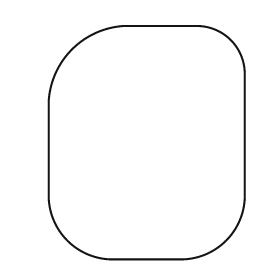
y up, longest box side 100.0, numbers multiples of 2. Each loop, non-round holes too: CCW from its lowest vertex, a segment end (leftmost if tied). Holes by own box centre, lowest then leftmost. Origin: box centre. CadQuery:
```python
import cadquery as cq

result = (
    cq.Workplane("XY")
    .moveTo(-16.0, -50.0)
    .lineTo(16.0, -50.0)
    .threePointArc((34.0, -42.0), (42.0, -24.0))
    .lineTo(42.0, 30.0)
    .threePointArc((36.0, 44.0), (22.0, 50.0))
    .lineTo(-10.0, 50.0)
    .threePointArc((-32.0, 40.0), (-42.0, 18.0))
    .lineTo(-42.0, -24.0)
    .threePointArc((-34.0, -42.0), (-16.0, -50.0))
    .close()
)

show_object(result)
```